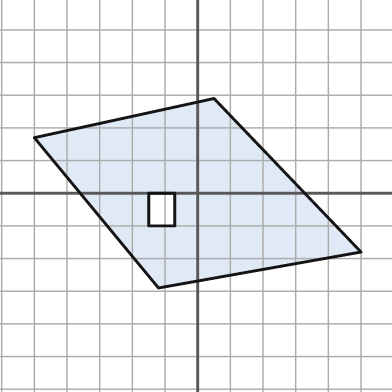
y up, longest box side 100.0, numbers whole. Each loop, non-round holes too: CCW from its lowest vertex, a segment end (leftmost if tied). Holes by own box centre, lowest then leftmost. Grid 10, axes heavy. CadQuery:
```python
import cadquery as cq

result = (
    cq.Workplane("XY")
    .moveTo(-12.0, -29.0)
    .lineTo(50.0, -18.0)
    .lineTo(5.0, 29.0)
    .lineTo(-50.0, 17.0)
    .close()
    .moveTo(-15.0, -10.0)
    .lineTo(-7.0, -10.0)
    .lineTo(-7.0, 0.0)
    .lineTo(-15.0, 0.0)
    .close()
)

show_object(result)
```